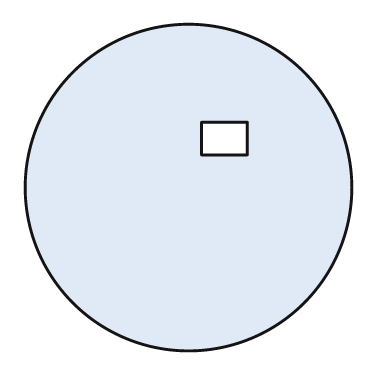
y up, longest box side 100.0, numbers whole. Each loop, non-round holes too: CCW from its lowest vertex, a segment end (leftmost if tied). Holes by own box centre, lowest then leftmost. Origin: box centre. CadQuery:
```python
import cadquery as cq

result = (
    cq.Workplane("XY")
    .moveTo(0.0, 0.0)
    .circle(50.0)
    .moveTo(4.0, 10.0)
    .lineTo(18.0, 10.0)
    .lineTo(18.0, 20.0)
    .lineTo(4.0, 20.0)
    .close()
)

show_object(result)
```